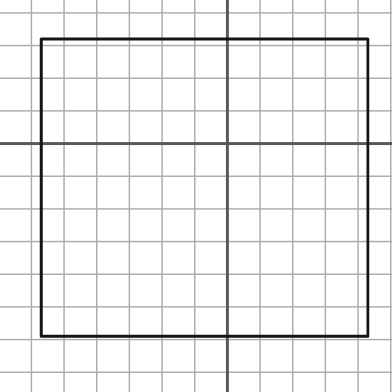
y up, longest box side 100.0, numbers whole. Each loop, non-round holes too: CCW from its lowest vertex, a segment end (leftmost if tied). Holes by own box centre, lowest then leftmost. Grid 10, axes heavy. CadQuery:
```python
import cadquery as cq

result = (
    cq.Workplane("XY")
    .moveTo(-57.0, -59.0)
    .lineTo(43.0, -59.0)
    .lineTo(43.0, 32.0)
    .lineTo(-57.0, 32.0)
    .close()
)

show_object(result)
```